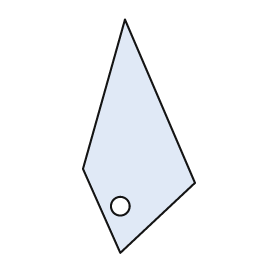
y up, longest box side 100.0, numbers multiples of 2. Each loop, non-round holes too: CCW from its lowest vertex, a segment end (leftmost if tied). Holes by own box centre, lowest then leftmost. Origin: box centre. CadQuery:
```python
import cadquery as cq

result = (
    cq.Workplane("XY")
    .moveTo(-8.0, -50.0)
    .lineTo(24.0, -20.0)
    .lineTo(-6.0, 50.0)
    .lineTo(-24.0, -14.0)
    .close()
    .moveTo(-8.0, -30.0)
    .circle(4.0)
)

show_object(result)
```